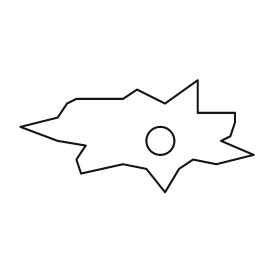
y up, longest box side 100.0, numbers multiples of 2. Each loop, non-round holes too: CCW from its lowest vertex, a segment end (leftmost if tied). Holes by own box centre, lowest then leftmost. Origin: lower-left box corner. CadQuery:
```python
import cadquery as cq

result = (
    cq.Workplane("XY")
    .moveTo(62.0, 0.0)
    .lineTo(68.0, 10.0)
    .lineTo(74.0, 14.0)
    .lineTo(84.0, 12.0)
    .lineTo(100.0, 16.0)
    .lineTo(86.0, 22.0)
    .lineTo(90.0, 24.0)
    .lineTo(92.0, 30.0)
    .lineTo(92.0, 34.0)
    .lineTo(76.0, 34.0)
    .lineTo(76.0, 48.0)
    .lineTo(62.0, 38.0)
    .lineTo(50.0, 44.0)
    .lineTo(44.0, 40.0)
    .lineTo(24.0, 40.0)
    .lineTo(20.0, 38.0)
    .lineTo(16.0, 32.0)
    .lineTo(0.0, 28.0)
    .lineTo(16.0, 22.0)
    .lineTo(28.0, 20.0)
    .lineTo(24.0, 14.0)
    .lineTo(26.0, 8.0)
    .lineTo(44.0, 12.0)
    .lineTo(54.0, 10.0)
    .close()
    .moveTo(60.0, 22.0)
    .circle(6.0)
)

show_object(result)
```